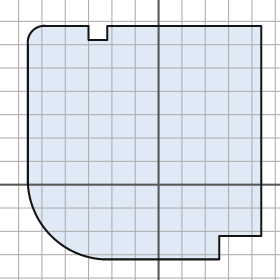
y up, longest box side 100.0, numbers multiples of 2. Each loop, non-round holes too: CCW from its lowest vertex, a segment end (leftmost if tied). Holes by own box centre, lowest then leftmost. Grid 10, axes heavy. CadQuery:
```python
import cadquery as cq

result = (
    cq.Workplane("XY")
    .moveTo(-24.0, -32.0)
    .lineTo(26.0, -32.0)
    .lineTo(26.0, -22.0)
    .lineTo(44.0, -22.0)
    .lineTo(44.0, 68.0)
    .lineTo(-22.0, 68.0)
    .lineTo(-22.0, 62.0)
    .lineTo(-30.0, 62.0)
    .lineTo(-30.0, 68.0)
    .lineTo(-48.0, 68.0)
    .threePointArc((-54.0, 66.0), (-56.0, 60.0))
    .lineTo(-56.0, 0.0)
    .threePointArc((-46.0, -22.0), (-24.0, -32.0))
    .close()
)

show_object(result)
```